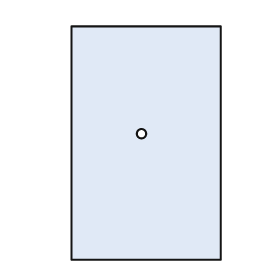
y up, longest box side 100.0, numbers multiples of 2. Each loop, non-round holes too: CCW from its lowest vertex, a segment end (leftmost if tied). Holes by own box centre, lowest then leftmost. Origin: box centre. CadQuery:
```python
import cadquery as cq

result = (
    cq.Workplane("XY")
    .moveTo(-32.0, -50.0)
    .lineTo(32.0, -50.0)
    .lineTo(32.0, 50.0)
    .lineTo(-32.0, 50.0)
    .close()
    .moveTo(-2.0, 4.0)
    .circle(2.0)
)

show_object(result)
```